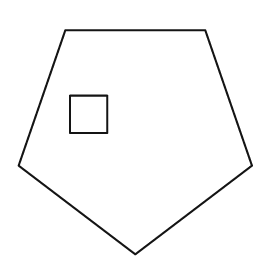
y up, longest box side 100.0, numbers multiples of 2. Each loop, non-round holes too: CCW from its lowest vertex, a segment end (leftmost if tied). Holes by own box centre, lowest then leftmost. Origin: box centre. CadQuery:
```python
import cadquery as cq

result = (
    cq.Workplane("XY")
    .moveTo(0.0, -48.0)
    .lineTo(50.0, -10.0)
    .lineTo(30.0, 48.0)
    .lineTo(-30.0, 48.0)
    .lineTo(-50.0, -10.0)
    .close()
    .moveTo(-28.0, 4.0)
    .lineTo(-12.0, 4.0)
    .lineTo(-12.0, 20.0)
    .lineTo(-28.0, 20.0)
    .close()
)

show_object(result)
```